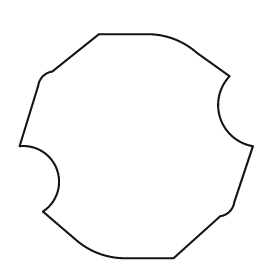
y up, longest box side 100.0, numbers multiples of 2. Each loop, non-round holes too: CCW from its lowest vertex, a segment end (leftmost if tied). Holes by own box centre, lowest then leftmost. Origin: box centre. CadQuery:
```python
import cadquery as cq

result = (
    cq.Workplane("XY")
    .moveTo(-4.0, -48.0)
    .lineTo(16.0, -48.0)
    .lineTo(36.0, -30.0)
    .threePointArc((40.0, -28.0), (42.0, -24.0))
    .lineTo(50.0, 0.0)
    .threePointArc((36.0, 12.0), (40.0, 30.0))
    .lineTo(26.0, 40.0)
    .threePointArc((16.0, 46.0), (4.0, 48.0))
    .lineTo(-16.0, 48.0)
    .lineTo(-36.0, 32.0)
    .threePointArc((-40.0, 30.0), (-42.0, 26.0))
    .lineTo(-50.0, 0.0)
    .threePointArc((-34.0, -10.0), (-40.0, -28.0))
    .lineTo(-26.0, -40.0)
    .threePointArc((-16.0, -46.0), (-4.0, -48.0))
    .close()
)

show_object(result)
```